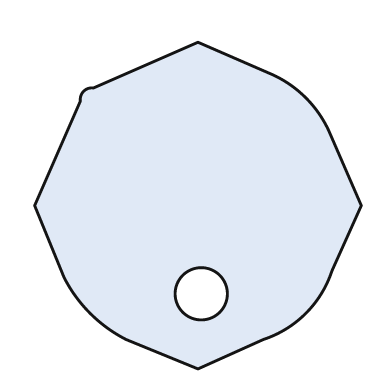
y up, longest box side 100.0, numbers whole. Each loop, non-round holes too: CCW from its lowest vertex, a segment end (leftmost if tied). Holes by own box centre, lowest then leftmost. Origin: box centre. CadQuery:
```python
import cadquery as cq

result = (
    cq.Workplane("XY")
    .moveTo(0.0, -50.0)
    .lineTo(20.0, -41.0)
    .threePointArc((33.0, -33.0), (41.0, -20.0))
    .lineTo(50.0, 0.0)
    .lineTo(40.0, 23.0)
    .threePointArc((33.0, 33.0), (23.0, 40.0))
    .lineTo(0.0, 50.0)
    .lineTo(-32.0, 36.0)
    .threePointArc((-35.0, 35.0), (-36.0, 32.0))
    .lineTo(-50.0, 0.0)
    .lineTo(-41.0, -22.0)
    .threePointArc((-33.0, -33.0), (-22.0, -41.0))
    .close()
    .moveTo(1.0, -27.0)
    .circle(8.0)
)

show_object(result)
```